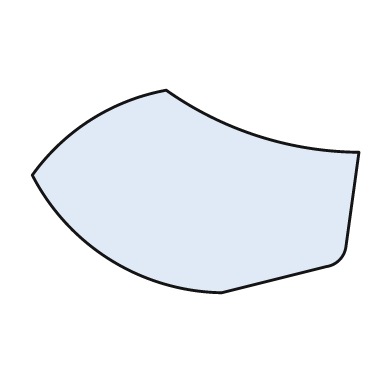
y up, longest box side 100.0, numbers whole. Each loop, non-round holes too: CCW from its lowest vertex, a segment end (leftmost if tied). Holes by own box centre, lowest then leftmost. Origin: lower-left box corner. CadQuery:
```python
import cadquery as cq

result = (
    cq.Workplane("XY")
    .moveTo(58.0, 0.0)
    .lineTo(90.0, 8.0)
    .threePointArc((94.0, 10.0), (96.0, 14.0))
    .lineTo(100.0, 43.0)
    .threePointArc((69.0, 48.0), (41.0, 62.0))
    .threePointArc((18.0, 53.0), (0.0, 36.0))
    .threePointArc((24.0, 10.0), (58.0, 0.0))
    .close()
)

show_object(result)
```